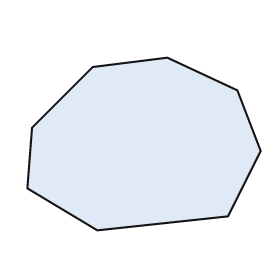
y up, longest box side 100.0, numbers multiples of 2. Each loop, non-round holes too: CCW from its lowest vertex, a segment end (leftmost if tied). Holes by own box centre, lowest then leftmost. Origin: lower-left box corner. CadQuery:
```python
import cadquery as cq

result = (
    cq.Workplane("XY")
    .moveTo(30.0, 0.0)
    .lineTo(86.0, 6.0)
    .lineTo(100.0, 34.0)
    .lineTo(90.0, 60.0)
    .lineTo(60.0, 74.0)
    .lineTo(28.0, 70.0)
    .lineTo(2.0, 44.0)
    .lineTo(0.0, 18.0)
    .close()
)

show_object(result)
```